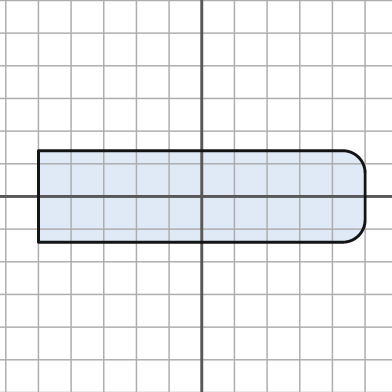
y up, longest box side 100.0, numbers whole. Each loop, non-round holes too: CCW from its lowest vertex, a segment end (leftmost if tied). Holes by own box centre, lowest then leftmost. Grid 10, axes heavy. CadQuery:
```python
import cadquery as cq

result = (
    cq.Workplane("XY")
    .moveTo(-50.0, -14.0)
    .lineTo(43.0, -14.0)
    .threePointArc((48.0, -12.0), (50.0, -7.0))
    .lineTo(50.0, 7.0)
    .threePointArc((48.0, 12.0), (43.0, 14.0))
    .lineTo(-50.0, 14.0)
    .close()
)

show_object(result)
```